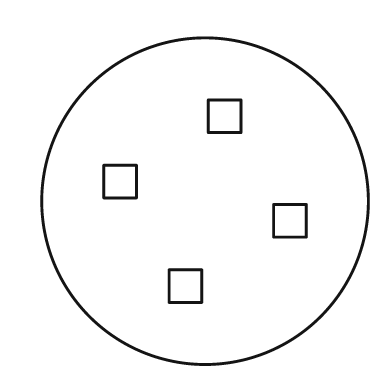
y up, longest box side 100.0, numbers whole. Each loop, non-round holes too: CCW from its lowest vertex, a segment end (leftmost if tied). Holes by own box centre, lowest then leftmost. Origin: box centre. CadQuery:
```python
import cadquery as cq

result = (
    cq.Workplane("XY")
    .moveTo(0.0, 0.0)
    .circle(50.0)
    .moveTo(-11.0, -31.0)
    .lineTo(-1.0, -31.0)
    .lineTo(-1.0, -21.0)
    .lineTo(-11.0, -21.0)
    .close()
    .moveTo(21.0, -11.0)
    .lineTo(31.0, -11.0)
    .lineTo(31.0, -1.0)
    .lineTo(21.0, -1.0)
    .close()
    .moveTo(-31.0, 1.0)
    .lineTo(-21.0, 1.0)
    .lineTo(-21.0, 11.0)
    .lineTo(-31.0, 11.0)
    .close()
    .moveTo(1.0, 21.0)
    .lineTo(11.0, 21.0)
    .lineTo(11.0, 31.0)
    .lineTo(1.0, 31.0)
    .close()
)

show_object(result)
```